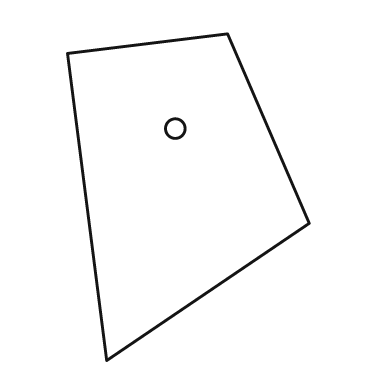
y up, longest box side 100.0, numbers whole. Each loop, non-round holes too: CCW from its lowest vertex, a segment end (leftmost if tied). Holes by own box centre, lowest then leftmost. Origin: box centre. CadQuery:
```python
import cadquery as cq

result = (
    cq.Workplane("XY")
    .moveTo(-25.0, -50.0)
    .lineTo(37.0, -8.0)
    .lineTo(12.0, 50.0)
    .lineTo(-37.0, 44.0)
    .close()
    .moveTo(-4.0, 21.0)
    .circle(3.0)
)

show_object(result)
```